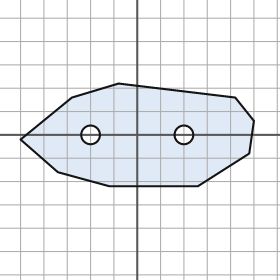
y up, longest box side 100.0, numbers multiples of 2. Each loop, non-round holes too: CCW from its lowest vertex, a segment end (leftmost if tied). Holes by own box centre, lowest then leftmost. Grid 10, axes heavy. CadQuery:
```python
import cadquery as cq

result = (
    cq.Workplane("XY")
    .moveTo(-12.0, -22.0)
    .lineTo(26.0, -22.0)
    .lineTo(48.0, -8.0)
    .lineTo(50.0, 6.0)
    .lineTo(42.0, 16.0)
    .lineTo(-8.0, 22.0)
    .lineTo(-28.0, 16.0)
    .lineTo(-50.0, -2.0)
    .lineTo(-34.0, -16.0)
    .close()
    .moveTo(-20.0, 0.0)
    .circle(4.0)
    .moveTo(20.0, 0.0)
    .circle(4.0)
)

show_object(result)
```